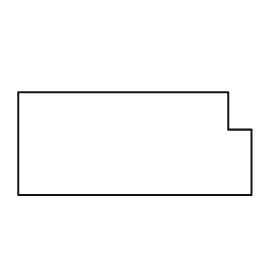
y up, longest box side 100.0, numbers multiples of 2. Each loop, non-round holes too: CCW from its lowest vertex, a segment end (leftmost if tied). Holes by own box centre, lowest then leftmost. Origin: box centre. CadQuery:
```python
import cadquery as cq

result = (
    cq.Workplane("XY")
    .moveTo(-50.0, -22.0)
    .lineTo(50.0, -22.0)
    .lineTo(50.0, 6.0)
    .lineTo(40.0, 6.0)
    .lineTo(40.0, 22.0)
    .lineTo(-50.0, 22.0)
    .close()
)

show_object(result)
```